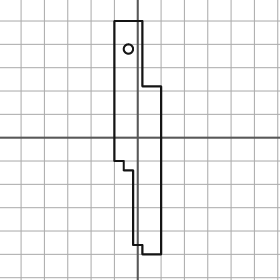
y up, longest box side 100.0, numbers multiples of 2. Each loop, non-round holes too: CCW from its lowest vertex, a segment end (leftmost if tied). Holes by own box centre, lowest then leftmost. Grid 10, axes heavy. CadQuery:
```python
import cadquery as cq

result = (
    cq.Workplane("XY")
    .moveTo(2.0, -50.0)
    .lineTo(10.0, -50.0)
    .lineTo(10.0, 22.0)
    .lineTo(2.0, 22.0)
    .lineTo(2.0, 50.0)
    .lineTo(-10.0, 50.0)
    .lineTo(-10.0, -10.0)
    .lineTo(-6.0, -10.0)
    .lineTo(-6.0, -14.0)
    .lineTo(-2.0, -14.0)
    .lineTo(-2.0, -46.0)
    .lineTo(2.0, -46.0)
    .close()
    .moveTo(-4.0, 38.0)
    .circle(2.0)
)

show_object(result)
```